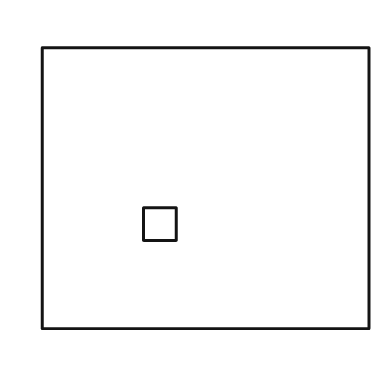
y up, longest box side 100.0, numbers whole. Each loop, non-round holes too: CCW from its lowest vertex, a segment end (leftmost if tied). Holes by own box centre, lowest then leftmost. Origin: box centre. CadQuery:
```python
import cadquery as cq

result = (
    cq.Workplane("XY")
    .moveTo(-50.0, -43.0)
    .lineTo(50.0, -43.0)
    .lineTo(50.0, 43.0)
    .lineTo(-50.0, 43.0)
    .close()
    .moveTo(-19.0, -16.0)
    .lineTo(-9.0, -16.0)
    .lineTo(-9.0, -6.0)
    .lineTo(-19.0, -6.0)
    .close()
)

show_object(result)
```